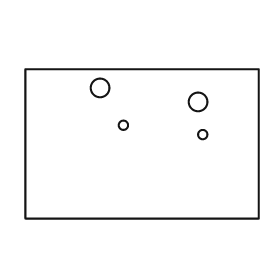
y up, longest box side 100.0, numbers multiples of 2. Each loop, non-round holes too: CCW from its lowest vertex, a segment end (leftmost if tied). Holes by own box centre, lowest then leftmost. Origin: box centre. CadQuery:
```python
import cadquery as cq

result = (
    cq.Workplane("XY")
    .moveTo(-50.0, -32.0)
    .lineTo(50.0, -32.0)
    .lineTo(50.0, 32.0)
    .lineTo(-50.0, 32.0)
    .close()
    .moveTo(26.0, 4.0)
    .circle(2.0)
    .moveTo(-8.0, 8.0)
    .circle(2.0)
    .moveTo(24.0, 18.0)
    .circle(4.0)
    .moveTo(-18.0, 24.0)
    .circle(4.0)
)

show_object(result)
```